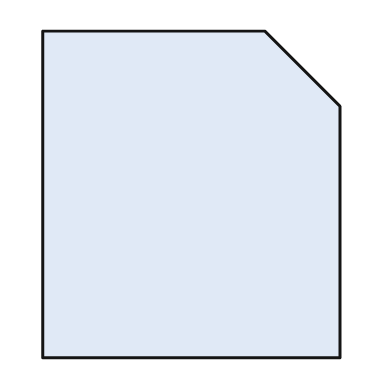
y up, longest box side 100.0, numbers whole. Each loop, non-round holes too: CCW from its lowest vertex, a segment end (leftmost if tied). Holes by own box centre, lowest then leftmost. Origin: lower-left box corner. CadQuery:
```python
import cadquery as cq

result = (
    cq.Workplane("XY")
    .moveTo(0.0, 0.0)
    .lineTo(91.0, 0.0)
    .lineTo(91.0, 77.0)
    .lineTo(68.0, 100.0)
    .lineTo(0.0, 100.0)
    .close()
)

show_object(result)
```